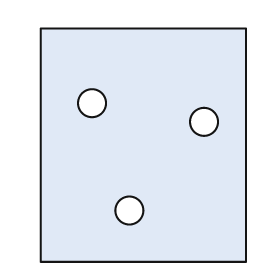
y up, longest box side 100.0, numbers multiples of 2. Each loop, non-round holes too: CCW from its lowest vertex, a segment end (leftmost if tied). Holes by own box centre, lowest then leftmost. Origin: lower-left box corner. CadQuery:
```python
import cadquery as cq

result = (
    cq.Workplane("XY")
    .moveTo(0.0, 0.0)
    .lineTo(88.0, 0.0)
    .lineTo(88.0, 100.0)
    .lineTo(0.0, 100.0)
    .close()
    .moveTo(38.0, 22.0)
    .circle(6.0)
    .moveTo(70.0, 60.0)
    .circle(6.0)
    .moveTo(22.0, 68.0)
    .circle(6.0)
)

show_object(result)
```